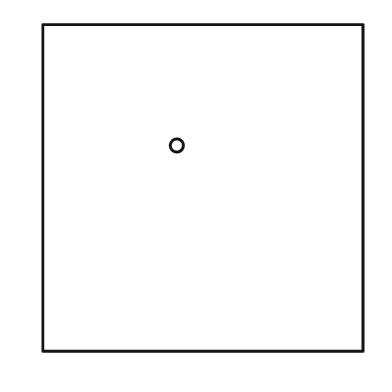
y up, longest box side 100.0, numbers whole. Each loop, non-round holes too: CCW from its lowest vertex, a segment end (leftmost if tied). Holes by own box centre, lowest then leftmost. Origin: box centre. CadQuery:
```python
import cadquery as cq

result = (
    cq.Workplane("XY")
    .moveTo(-49.0, -50.0)
    .lineTo(49.0, -50.0)
    .lineTo(49.0, 50.0)
    .lineTo(-49.0, 50.0)
    .close()
    .moveTo(-8.0, 13.0)
    .circle(2.0)
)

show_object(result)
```